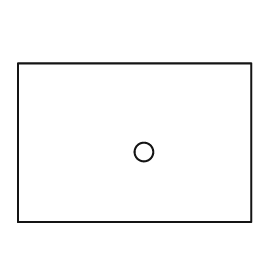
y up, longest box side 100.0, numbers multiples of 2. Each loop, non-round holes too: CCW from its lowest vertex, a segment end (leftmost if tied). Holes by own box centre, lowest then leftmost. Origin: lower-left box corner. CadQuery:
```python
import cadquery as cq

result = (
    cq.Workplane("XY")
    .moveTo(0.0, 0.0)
    .lineTo(100.0, 0.0)
    .lineTo(100.0, 68.0)
    .lineTo(0.0, 68.0)
    .close()
    .moveTo(54.0, 30.0)
    .circle(4.0)
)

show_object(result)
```